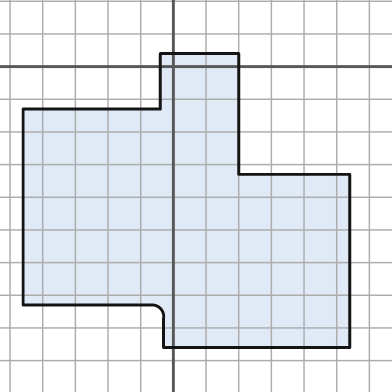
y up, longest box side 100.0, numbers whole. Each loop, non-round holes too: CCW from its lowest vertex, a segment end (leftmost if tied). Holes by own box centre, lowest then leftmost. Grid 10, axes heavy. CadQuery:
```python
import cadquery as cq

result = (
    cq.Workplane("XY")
    .moveTo(-3.0, -86.0)
    .lineTo(54.0, -86.0)
    .lineTo(54.0, -33.0)
    .lineTo(20.0, -33.0)
    .lineTo(20.0, 4.0)
    .lineTo(-4.0, 4.0)
    .lineTo(-4.0, -13.0)
    .lineTo(-46.0, -13.0)
    .lineTo(-46.0, -73.0)
    .lineTo(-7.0, -73.0)
    .threePointArc((-4.0, -74.0), (-3.0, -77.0))
    .close()
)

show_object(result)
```